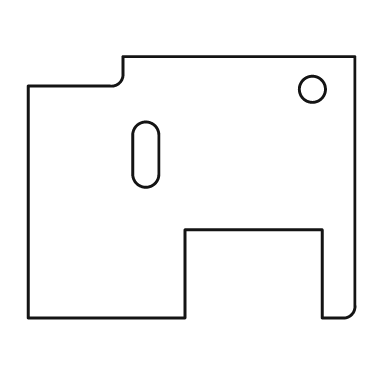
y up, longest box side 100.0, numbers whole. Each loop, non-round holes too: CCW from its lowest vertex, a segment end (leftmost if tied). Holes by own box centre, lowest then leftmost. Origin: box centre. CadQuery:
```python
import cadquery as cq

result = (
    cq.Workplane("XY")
    .moveTo(-50.0, -40.0)
    .lineTo(-2.0, -40.0)
    .lineTo(-2.0, -13.0)
    .lineTo(40.0, -13.0)
    .lineTo(40.0, -40.0)
    .lineTo(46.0, -40.0)
    .threePointArc((49.0, -39.0), (50.0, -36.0))
    .lineTo(50.0, 40.0)
    .lineTo(-21.0, 40.0)
    .lineTo(-21.0, 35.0)
    .threePointArc((-22.0, 32.0), (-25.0, 31.0))
    .lineTo(-50.0, 31.0)
    .close()
    .moveTo(-18.0, 4.0)
    .threePointArc((-14.0, 0.0), (-10.0, 4.0))
    .lineTo(-10.0, 16.0)
    .threePointArc((-14.0, 20.0), (-18.0, 16.0))
    .close()
    .moveTo(37.0, 30.0)
    .circle(4.0)
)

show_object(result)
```